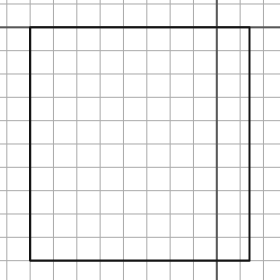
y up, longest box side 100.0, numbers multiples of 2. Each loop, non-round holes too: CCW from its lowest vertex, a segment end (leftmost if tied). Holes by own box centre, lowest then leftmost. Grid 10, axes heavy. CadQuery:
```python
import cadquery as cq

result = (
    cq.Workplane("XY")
    .moveTo(-80.0, -100.0)
    .lineTo(14.0, -100.0)
    .lineTo(14.0, 0.0)
    .lineTo(-80.0, 0.0)
    .close()
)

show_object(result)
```